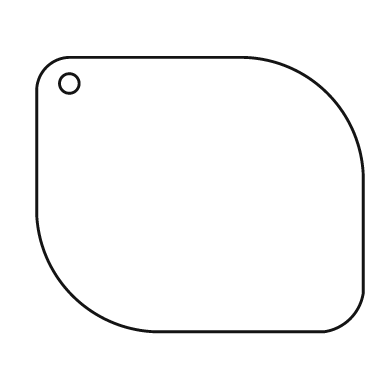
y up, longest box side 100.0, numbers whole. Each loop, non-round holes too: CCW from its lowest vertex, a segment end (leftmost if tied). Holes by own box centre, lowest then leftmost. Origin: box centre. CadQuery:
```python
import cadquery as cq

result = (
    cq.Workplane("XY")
    .moveTo(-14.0, -42.0)
    .lineTo(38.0, -42.0)
    .threePointArc((46.0, -38.0), (50.0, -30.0))
    .lineTo(50.0, 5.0)
    .threePointArc((39.0, 31.0), (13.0, 42.0))
    .lineTo(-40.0, 42.0)
    .threePointArc((-47.0, 39.0), (-50.0, 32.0))
    .lineTo(-50.0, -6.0)
    .threePointArc((-39.0, -31.0), (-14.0, -42.0))
    .close()
    .moveTo(-40.0, 34.0)
    .circle(3.0)
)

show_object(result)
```